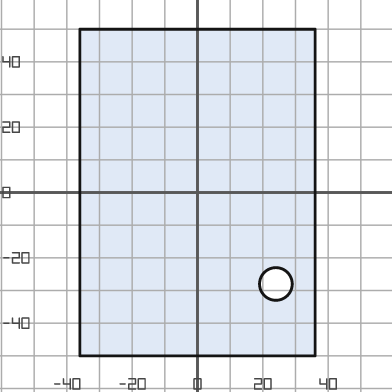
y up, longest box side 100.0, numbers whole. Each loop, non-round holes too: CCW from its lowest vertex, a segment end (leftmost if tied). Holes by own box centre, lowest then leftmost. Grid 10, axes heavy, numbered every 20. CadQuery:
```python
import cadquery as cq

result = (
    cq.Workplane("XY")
    .moveTo(-36.0, -50.0)
    .lineTo(36.0, -50.0)
    .lineTo(36.0, 50.0)
    .lineTo(-36.0, 50.0)
    .close()
    .moveTo(24.0, -28.0)
    .circle(5.0)
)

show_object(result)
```